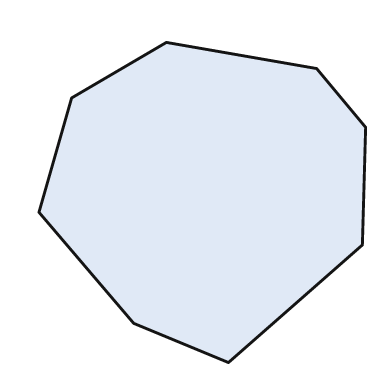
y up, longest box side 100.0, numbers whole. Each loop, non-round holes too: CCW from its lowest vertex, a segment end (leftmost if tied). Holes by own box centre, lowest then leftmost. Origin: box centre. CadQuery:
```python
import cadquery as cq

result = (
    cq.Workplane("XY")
    .moveTo(8.0, -49.0)
    .lineTo(49.0, -13.0)
    .lineTo(50.0, 23.0)
    .lineTo(35.0, 41.0)
    .lineTo(-11.0, 49.0)
    .lineTo(-40.0, 32.0)
    .lineTo(-50.0, -3.0)
    .lineTo(-21.0, -37.0)
    .close()
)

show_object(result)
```